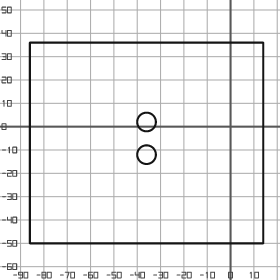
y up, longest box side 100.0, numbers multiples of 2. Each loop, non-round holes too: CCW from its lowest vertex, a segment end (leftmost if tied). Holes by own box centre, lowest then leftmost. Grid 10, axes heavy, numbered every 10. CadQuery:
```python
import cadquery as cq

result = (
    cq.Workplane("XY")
    .moveTo(-86.0, -50.0)
    .lineTo(14.0, -50.0)
    .lineTo(14.0, 36.0)
    .lineTo(-86.0, 36.0)
    .close()
    .moveTo(-36.0, -12.0)
    .circle(4.0)
    .moveTo(-36.0, 2.0)
    .circle(4.0)
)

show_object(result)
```